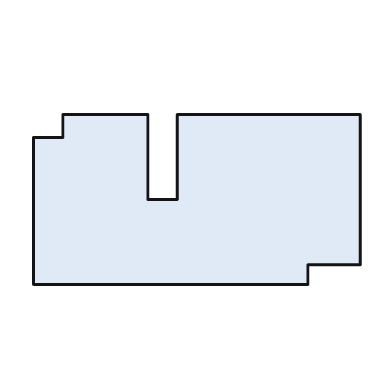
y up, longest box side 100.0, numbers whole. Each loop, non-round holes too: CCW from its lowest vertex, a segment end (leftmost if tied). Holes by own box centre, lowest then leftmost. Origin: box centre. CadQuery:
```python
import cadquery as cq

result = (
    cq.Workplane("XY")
    .moveTo(-50.0, -26.0)
    .lineTo(34.0, -26.0)
    .lineTo(34.0, -20.0)
    .lineTo(50.0, -20.0)
    .lineTo(50.0, 26.0)
    .lineTo(-6.0, 26.0)
    .lineTo(-6.0, 0.0)
    .lineTo(-15.0, 0.0)
    .lineTo(-15.0, 26.0)
    .lineTo(-41.0, 26.0)
    .lineTo(-41.0, 19.0)
    .lineTo(-50.0, 19.0)
    .close()
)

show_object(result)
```